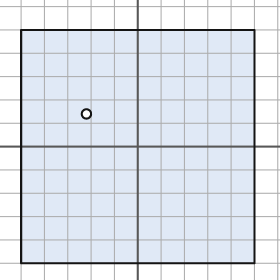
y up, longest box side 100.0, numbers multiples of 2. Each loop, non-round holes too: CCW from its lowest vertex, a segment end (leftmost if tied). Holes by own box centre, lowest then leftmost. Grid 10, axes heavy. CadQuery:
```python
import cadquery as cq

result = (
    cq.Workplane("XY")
    .moveTo(-50.0, -50.0)
    .lineTo(50.0, -50.0)
    .lineTo(50.0, 50.0)
    .lineTo(-50.0, 50.0)
    .close()
    .moveTo(-22.0, 14.0)
    .circle(2.0)
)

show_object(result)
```